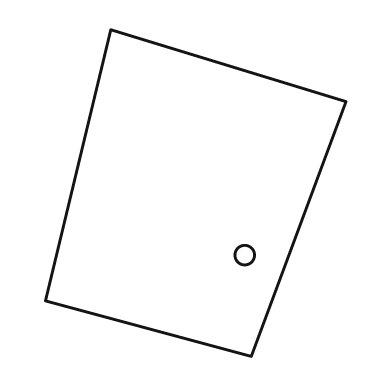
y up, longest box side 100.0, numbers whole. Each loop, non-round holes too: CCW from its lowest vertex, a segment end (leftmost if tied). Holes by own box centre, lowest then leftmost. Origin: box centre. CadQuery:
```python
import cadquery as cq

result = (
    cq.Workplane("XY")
    .moveTo(17.0, -50.0)
    .lineTo(46.0, 28.0)
    .lineTo(-26.0, 50.0)
    .lineTo(-46.0, -33.0)
    .close()
    .moveTo(15.0, -19.0)
    .circle(3.0)
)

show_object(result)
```